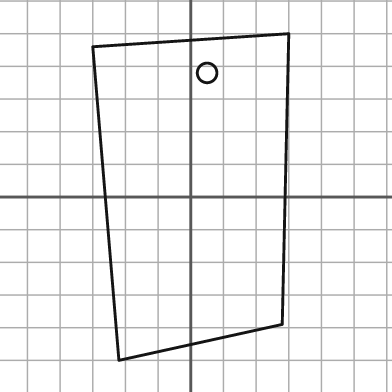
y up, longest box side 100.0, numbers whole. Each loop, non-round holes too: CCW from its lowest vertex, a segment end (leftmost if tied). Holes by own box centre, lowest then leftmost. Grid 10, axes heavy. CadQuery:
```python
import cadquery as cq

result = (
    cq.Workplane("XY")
    .moveTo(-22.0, -50.0)
    .lineTo(28.0, -39.0)
    .lineTo(30.0, 50.0)
    .lineTo(-30.0, 46.0)
    .close()
    .moveTo(5.0, 38.0)
    .circle(3.0)
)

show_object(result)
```